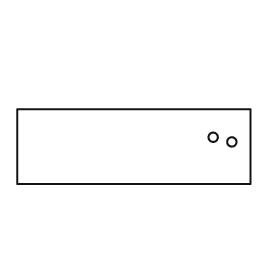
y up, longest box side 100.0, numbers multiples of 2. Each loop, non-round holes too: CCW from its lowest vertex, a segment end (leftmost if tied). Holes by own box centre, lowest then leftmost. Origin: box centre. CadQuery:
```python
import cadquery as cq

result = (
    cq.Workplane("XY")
    .moveTo(-50.0, -16.0)
    .lineTo(50.0, -16.0)
    .lineTo(50.0, 16.0)
    .lineTo(-50.0, 16.0)
    .close()
    .moveTo(42.0, 2.0)
    .circle(2.0)
    .moveTo(34.0, 4.0)
    .circle(2.0)
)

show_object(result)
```